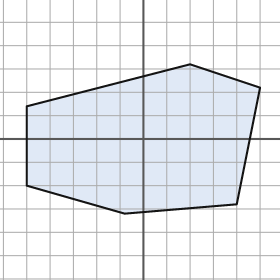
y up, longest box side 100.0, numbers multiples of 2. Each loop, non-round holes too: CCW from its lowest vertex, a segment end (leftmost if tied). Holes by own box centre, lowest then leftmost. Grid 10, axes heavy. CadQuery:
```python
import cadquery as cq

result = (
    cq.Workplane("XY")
    .moveTo(-8.0, -32.0)
    .lineTo(40.0, -28.0)
    .lineTo(50.0, 22.0)
    .lineTo(20.0, 32.0)
    .lineTo(-50.0, 14.0)
    .lineTo(-50.0, -20.0)
    .close()
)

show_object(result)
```